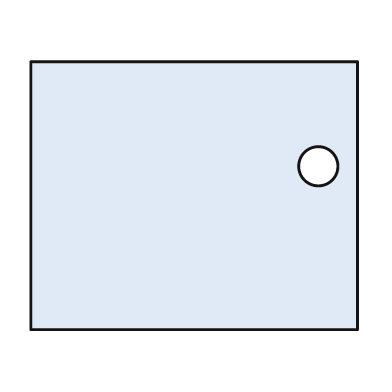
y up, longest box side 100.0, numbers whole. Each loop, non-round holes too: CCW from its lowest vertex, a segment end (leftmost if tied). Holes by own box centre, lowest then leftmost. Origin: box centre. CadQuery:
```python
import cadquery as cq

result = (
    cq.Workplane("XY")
    .moveTo(-50.0, -41.0)
    .lineTo(50.0, -41.0)
    .lineTo(50.0, 41.0)
    .lineTo(-50.0, 41.0)
    .close()
    .moveTo(38.0, 9.0)
    .circle(6.0)
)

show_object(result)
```